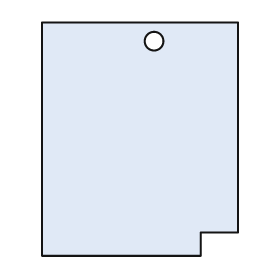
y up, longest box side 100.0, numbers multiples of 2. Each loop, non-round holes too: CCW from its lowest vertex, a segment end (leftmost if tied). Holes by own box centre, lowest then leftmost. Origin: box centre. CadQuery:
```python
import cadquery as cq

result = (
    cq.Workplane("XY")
    .moveTo(-42.0, -50.0)
    .lineTo(26.0, -50.0)
    .lineTo(26.0, -40.0)
    .lineTo(42.0, -40.0)
    .lineTo(42.0, 50.0)
    .lineTo(-42.0, 50.0)
    .close()
    .moveTo(6.0, 42.0)
    .circle(4.0)
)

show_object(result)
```